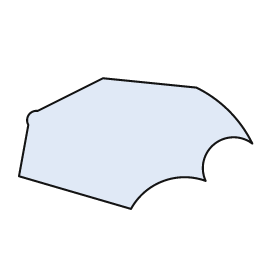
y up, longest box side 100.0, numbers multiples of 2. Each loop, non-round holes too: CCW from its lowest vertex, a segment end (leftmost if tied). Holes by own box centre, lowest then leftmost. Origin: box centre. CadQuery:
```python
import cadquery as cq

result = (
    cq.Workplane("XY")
    .moveTo(-2.0, -28.0)
    .threePointArc((12.0, -16.0), (30.0, -16.0))
    .threePointArc((34.0, 0.0), (50.0, 0.0))
    .threePointArc((40.0, 14.0), (26.0, 24.0))
    .lineTo(-14.0, 28.0)
    .lineTo(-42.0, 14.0)
    .threePointArc((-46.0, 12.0), (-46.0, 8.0))
    .lineTo(-50.0, -14.0)
    .close()
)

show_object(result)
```